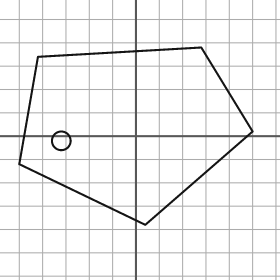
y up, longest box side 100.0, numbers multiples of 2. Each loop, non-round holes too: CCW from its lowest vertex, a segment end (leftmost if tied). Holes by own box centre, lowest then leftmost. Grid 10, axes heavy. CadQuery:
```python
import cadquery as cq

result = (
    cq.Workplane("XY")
    .moveTo(4.0, -38.0)
    .lineTo(50.0, 2.0)
    .lineTo(28.0, 38.0)
    .lineTo(-42.0, 34.0)
    .lineTo(-50.0, -12.0)
    .close()
    .moveTo(-32.0, -2.0)
    .circle(4.0)
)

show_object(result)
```